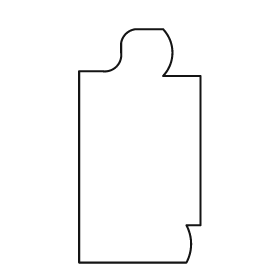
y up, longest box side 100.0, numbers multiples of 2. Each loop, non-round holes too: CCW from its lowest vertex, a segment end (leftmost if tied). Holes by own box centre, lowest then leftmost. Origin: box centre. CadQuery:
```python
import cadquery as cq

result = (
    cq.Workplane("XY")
    .moveTo(-26.0, -50.0)
    .lineTo(20.0, -50.0)
    .threePointArc((22.0, -42.0), (20.0, -34.0))
    .lineTo(26.0, -34.0)
    .lineTo(26.0, 30.0)
    .lineTo(10.0, 30.0)
    .threePointArc((14.0, 40.0), (10.0, 50.0))
    .lineTo(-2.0, 50.0)
    .threePointArc((-6.0, 48.0), (-8.0, 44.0))
    .lineTo(-8.0, 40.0)
    .threePointArc((-10.0, 34.0), (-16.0, 32.0))
    .lineTo(-26.0, 32.0)
    .close()
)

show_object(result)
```